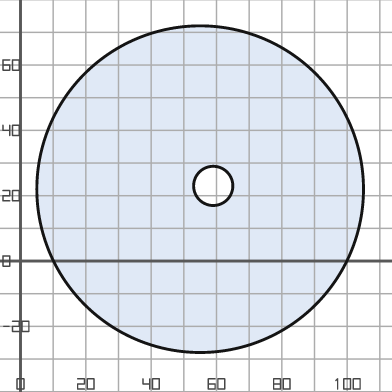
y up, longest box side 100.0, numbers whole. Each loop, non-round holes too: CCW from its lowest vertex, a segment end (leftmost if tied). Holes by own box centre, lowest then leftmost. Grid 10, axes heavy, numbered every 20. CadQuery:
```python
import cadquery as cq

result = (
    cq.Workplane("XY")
    .moveTo(55.0, 22.0)
    .circle(50.0)
    .moveTo(59.0, 23.0)
    .circle(6.0)
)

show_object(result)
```